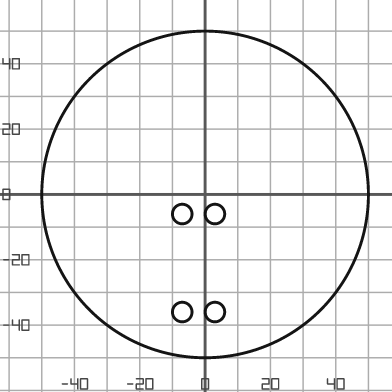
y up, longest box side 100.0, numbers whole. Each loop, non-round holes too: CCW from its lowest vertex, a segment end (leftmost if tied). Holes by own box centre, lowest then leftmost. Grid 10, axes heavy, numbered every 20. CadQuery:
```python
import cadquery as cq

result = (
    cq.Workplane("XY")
    .moveTo(0.0, 0.0)
    .circle(50.0)
    .moveTo(-7.0, -36.0)
    .circle(3.0)
    .moveTo(3.0, -36.0)
    .circle(3.0)
    .moveTo(-7.0, -6.0)
    .circle(3.0)
    .moveTo(3.0, -6.0)
    .circle(3.0)
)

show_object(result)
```